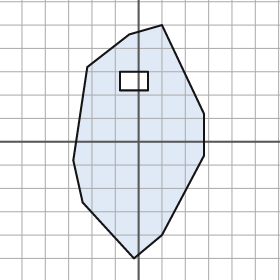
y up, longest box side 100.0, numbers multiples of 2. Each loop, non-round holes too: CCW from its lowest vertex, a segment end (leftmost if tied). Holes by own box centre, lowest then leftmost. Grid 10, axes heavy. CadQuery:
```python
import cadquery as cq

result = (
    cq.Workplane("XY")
    .moveTo(-2.0, -50.0)
    .lineTo(10.0, -40.0)
    .lineTo(28.0, -6.0)
    .lineTo(28.0, 12.0)
    .lineTo(10.0, 50.0)
    .lineTo(-4.0, 46.0)
    .lineTo(-22.0, 32.0)
    .lineTo(-28.0, -8.0)
    .lineTo(-24.0, -26.0)
    .close()
    .moveTo(-8.0, 22.0)
    .lineTo(4.0, 22.0)
    .lineTo(4.0, 30.0)
    .lineTo(-8.0, 30.0)
    .close()
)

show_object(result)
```